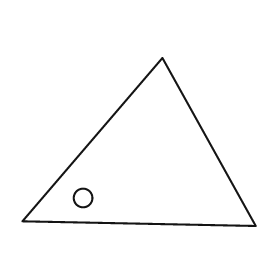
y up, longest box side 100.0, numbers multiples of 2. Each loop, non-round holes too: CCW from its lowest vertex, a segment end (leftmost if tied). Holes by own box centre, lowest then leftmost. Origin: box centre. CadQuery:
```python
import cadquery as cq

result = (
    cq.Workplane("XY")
    .moveTo(50.0, -36.0)
    .lineTo(10.0, 36.0)
    .lineTo(-50.0, -34.0)
    .close()
    .moveTo(-24.0, -24.0)
    .circle(4.0)
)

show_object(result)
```